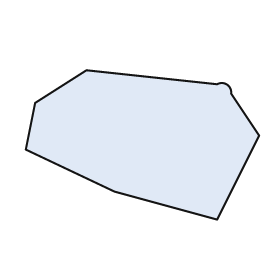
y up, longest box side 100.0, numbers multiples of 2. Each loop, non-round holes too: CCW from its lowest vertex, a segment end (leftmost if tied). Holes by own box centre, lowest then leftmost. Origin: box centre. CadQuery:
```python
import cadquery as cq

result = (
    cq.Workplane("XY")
    .moveTo(32.0, -32.0)
    .lineTo(50.0, 4.0)
    .lineTo(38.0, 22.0)
    .threePointArc((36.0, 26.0), (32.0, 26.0))
    .lineTo(-24.0, 32.0)
    .lineTo(-46.0, 18.0)
    .lineTo(-50.0, -2.0)
    .lineTo(-12.0, -20.0)
    .close()
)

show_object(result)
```